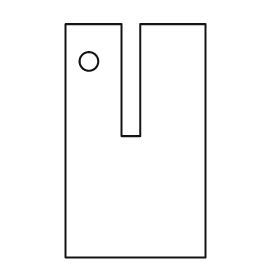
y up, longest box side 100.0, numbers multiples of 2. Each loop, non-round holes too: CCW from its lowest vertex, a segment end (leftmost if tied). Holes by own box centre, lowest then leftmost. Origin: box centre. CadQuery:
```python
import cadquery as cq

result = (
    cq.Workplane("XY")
    .moveTo(-30.0, -50.0)
    .lineTo(30.0, -50.0)
    .lineTo(30.0, 50.0)
    .lineTo(2.0, 50.0)
    .lineTo(2.0, 2.0)
    .lineTo(-6.0, 2.0)
    .lineTo(-6.0, 50.0)
    .lineTo(-30.0, 50.0)
    .close()
    .moveTo(-20.0, 34.0)
    .circle(4.0)
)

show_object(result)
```